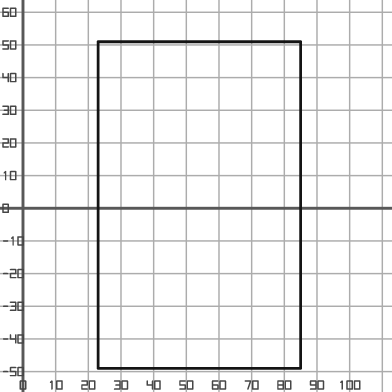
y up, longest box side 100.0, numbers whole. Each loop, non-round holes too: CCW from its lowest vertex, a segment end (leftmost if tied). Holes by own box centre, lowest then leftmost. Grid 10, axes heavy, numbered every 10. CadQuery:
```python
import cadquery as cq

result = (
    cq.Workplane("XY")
    .moveTo(23.0, -49.0)
    .lineTo(85.0, -49.0)
    .lineTo(85.0, 51.0)
    .lineTo(23.0, 51.0)
    .close()
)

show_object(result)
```